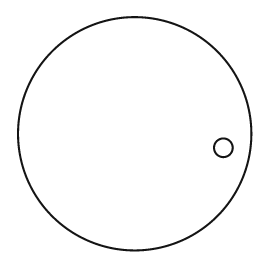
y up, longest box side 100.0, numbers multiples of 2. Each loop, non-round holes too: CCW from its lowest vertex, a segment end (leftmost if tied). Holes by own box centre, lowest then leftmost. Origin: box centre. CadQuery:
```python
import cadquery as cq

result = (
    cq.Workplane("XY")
    .moveTo(0.0, 0.0)
    .circle(50.0)
    .moveTo(38.0, -6.0)
    .circle(4.0)
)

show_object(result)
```